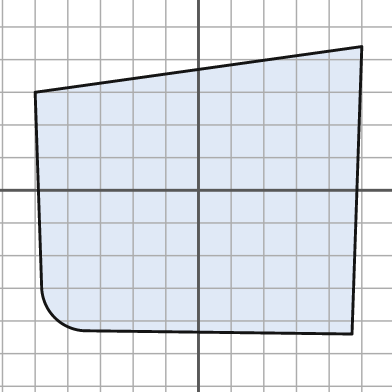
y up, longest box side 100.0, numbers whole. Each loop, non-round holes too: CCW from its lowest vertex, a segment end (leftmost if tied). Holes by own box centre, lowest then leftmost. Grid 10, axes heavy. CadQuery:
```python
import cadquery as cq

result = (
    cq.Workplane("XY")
    .moveTo(47.0, -44.0)
    .lineTo(50.0, 44.0)
    .lineTo(-50.0, 30.0)
    .lineTo(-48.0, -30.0)
    .threePointArc((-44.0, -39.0), (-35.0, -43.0))
    .close()
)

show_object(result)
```